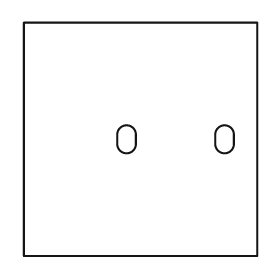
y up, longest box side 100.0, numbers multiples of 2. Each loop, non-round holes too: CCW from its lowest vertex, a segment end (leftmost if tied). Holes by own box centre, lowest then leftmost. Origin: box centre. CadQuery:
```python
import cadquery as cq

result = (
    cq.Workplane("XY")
    .moveTo(-50.0, -50.0)
    .lineTo(50.0, -50.0)
    .lineTo(50.0, 50.0)
    .lineTo(-50.0, 50.0)
    .close()
    .moveTo(-10.0, -2.0)
    .threePointArc((-6.0, -6.0), (-2.0, -2.0))
    .lineTo(-2.0, 2.0)
    .threePointArc((-6.0, 6.0), (-10.0, 2.0))
    .close()
    .moveTo(32.0, -2.0)
    .threePointArc((36.0, -6.0), (40.0, -2.0))
    .lineTo(40.0, 2.0)
    .threePointArc((36.0, 6.0), (32.0, 2.0))
    .close()
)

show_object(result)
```